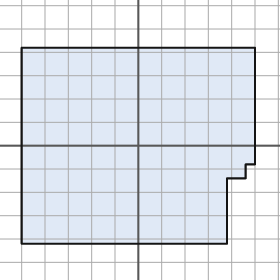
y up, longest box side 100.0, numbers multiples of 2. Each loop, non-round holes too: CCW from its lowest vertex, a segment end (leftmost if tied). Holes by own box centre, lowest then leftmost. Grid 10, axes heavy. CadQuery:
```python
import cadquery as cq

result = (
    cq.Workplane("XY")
    .moveTo(-50.0, -42.0)
    .lineTo(38.0, -42.0)
    .lineTo(38.0, -14.0)
    .lineTo(46.0, -14.0)
    .lineTo(46.0, -8.0)
    .lineTo(50.0, -8.0)
    .lineTo(50.0, 42.0)
    .lineTo(-50.0, 42.0)
    .close()
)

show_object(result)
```